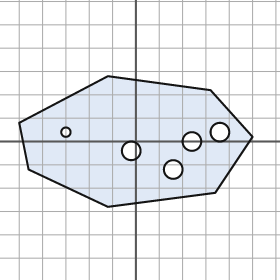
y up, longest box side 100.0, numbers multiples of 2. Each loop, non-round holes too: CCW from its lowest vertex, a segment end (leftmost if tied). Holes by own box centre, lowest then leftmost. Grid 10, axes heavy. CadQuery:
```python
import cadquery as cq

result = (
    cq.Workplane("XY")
    .moveTo(-12.0, -28.0)
    .lineTo(34.0, -22.0)
    .lineTo(50.0, 2.0)
    .lineTo(32.0, 22.0)
    .lineTo(-12.0, 28.0)
    .lineTo(-50.0, 8.0)
    .lineTo(-46.0, -12.0)
    .close()
    .moveTo(16.0, -12.0)
    .circle(4.0)
    .moveTo(-2.0, -4.0)
    .circle(4.0)
    .moveTo(24.0, 0.0)
    .circle(4.0)
    .moveTo(-30.0, 4.0)
    .circle(2.0)
    .moveTo(36.0, 4.0)
    .circle(4.0)
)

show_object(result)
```